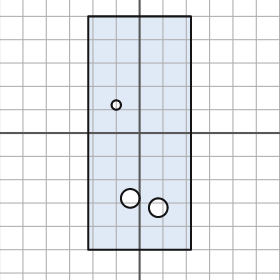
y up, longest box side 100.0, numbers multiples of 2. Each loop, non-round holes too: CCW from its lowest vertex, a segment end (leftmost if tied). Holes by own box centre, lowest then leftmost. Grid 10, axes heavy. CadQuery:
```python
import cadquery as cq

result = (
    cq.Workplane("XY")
    .moveTo(-22.0, -50.0)
    .lineTo(22.0, -50.0)
    .lineTo(22.0, 50.0)
    .lineTo(-22.0, 50.0)
    .close()
    .moveTo(8.0, -32.0)
    .circle(4.0)
    .moveTo(-4.0, -28.0)
    .circle(4.0)
    .moveTo(-10.0, 12.0)
    .circle(2.0)
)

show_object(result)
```